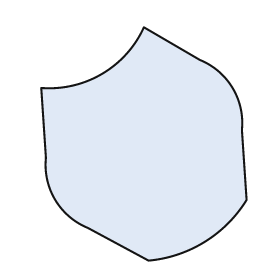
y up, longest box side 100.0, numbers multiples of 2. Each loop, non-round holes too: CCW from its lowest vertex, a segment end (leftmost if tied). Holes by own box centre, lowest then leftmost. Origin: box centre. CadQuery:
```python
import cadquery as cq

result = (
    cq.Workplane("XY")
    .moveTo(2.0, -50.0)
    .threePointArc((26.0, -42.0), (44.0, -24.0))
    .lineTo(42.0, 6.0)
    .threePointArc((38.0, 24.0), (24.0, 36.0))
    .lineTo(0.0, 50.0)
    .threePointArc((-18.0, 30.0), (-44.0, 24.0))
    .lineTo(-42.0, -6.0)
    .threePointArc((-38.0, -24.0), (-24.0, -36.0))
    .close()
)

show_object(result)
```